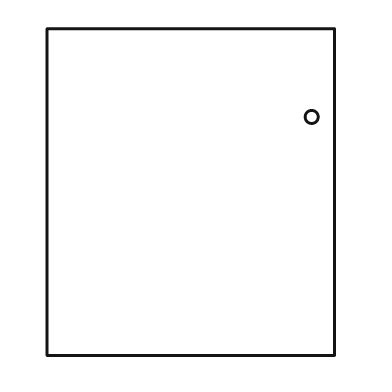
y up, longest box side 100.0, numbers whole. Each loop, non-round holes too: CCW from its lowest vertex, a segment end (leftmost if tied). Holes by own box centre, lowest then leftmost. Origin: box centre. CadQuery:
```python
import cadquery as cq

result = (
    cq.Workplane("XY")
    .moveTo(-44.0, -50.0)
    .lineTo(44.0, -50.0)
    .lineTo(44.0, 50.0)
    .lineTo(-44.0, 50.0)
    .close()
    .moveTo(37.0, 23.0)
    .circle(2.0)
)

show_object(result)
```